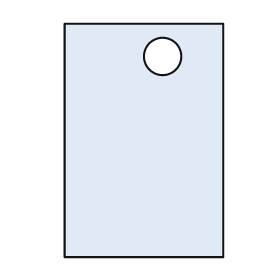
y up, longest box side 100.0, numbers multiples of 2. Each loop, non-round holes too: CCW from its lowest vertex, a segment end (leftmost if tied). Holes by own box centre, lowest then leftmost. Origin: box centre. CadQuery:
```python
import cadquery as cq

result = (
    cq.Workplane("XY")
    .moveTo(-34.0, -50.0)
    .lineTo(34.0, -50.0)
    .lineTo(34.0, 50.0)
    .lineTo(-34.0, 50.0)
    .close()
    .moveTo(8.0, 36.0)
    .circle(8.0)
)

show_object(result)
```